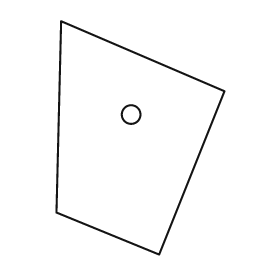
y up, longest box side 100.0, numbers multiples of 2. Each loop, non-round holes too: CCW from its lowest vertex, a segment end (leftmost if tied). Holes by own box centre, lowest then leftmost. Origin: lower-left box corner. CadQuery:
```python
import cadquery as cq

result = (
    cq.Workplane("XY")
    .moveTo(44.0, 0.0)
    .lineTo(72.0, 70.0)
    .lineTo(2.0, 100.0)
    .lineTo(0.0, 18.0)
    .close()
    .moveTo(32.0, 60.0)
    .circle(4.0)
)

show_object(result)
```